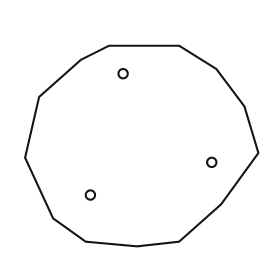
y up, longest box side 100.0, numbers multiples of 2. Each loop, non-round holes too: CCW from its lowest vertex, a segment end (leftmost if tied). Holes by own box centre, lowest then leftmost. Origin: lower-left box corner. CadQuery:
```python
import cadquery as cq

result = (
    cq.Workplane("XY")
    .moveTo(48.0, 0.0)
    .lineTo(66.0, 2.0)
    .lineTo(84.0, 18.0)
    .lineTo(100.0, 40.0)
    .lineTo(94.0, 60.0)
    .lineTo(82.0, 76.0)
    .lineTo(66.0, 86.0)
    .lineTo(36.0, 86.0)
    .lineTo(24.0, 80.0)
    .lineTo(6.0, 64.0)
    .lineTo(0.0, 38.0)
    .lineTo(12.0, 12.0)
    .lineTo(26.0, 2.0)
    .close()
    .moveTo(28.0, 22.0)
    .circle(2.0)
    .moveTo(80.0, 36.0)
    .circle(2.0)
    .moveTo(42.0, 74.0)
    .circle(2.0)
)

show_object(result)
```